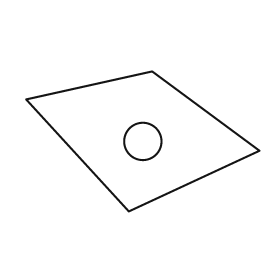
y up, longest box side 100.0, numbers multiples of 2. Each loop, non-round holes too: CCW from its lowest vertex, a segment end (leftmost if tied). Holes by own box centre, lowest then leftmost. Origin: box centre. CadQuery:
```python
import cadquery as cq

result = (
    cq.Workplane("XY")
    .moveTo(-6.0, -30.0)
    .lineTo(50.0, -4.0)
    .lineTo(4.0, 30.0)
    .lineTo(-50.0, 18.0)
    .close()
    .moveTo(0.0, 0.0)
    .circle(8.0)
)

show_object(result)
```